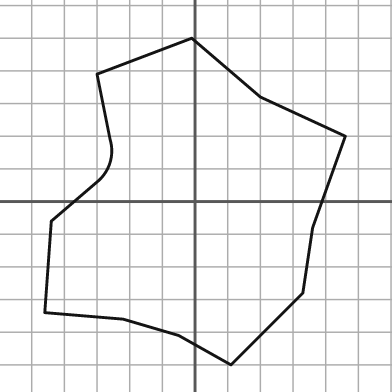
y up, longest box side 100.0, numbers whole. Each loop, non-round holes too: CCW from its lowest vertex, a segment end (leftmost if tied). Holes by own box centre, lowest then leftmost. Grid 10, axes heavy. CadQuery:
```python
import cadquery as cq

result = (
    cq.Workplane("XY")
    .moveTo(11.0, -50.0)
    .lineTo(33.0, -28.0)
    .lineTo(36.0, -8.0)
    .lineTo(46.0, 20.0)
    .lineTo(20.0, 32.0)
    .lineTo(-1.0, 50.0)
    .lineTo(-30.0, 39.0)
    .lineTo(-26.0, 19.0)
    .threePointArc((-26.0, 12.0), (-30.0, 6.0))
    .lineTo(-44.0, -6.0)
    .lineTo(-46.0, -34.0)
    .lineTo(-22.0, -36.0)
    .lineTo(-5.0, -41.0)
    .close()
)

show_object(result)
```